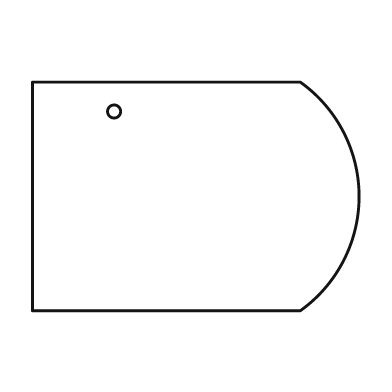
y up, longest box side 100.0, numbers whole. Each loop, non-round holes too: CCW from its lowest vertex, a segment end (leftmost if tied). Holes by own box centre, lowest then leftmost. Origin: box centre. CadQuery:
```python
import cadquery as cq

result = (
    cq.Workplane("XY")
    .moveTo(-50.0, -35.0)
    .lineTo(32.0, -35.0)
    .threePointArc((50.0, 0.0), (32.0, 35.0))
    .lineTo(-50.0, 35.0)
    .close()
    .moveTo(-25.0, 26.0)
    .circle(2.0)
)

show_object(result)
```